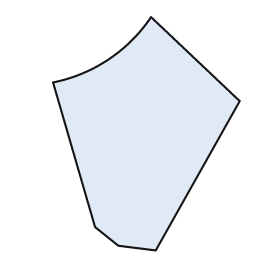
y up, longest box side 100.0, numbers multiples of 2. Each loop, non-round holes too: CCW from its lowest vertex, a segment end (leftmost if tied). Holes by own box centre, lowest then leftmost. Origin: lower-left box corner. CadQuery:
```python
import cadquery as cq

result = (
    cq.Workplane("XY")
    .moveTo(44.0, 0.0)
    .lineTo(80.0, 64.0)
    .lineTo(42.0, 100.0)
    .threePointArc((24.0, 82.0), (0.0, 72.0))
    .lineTo(18.0, 10.0)
    .lineTo(28.0, 2.0)
    .close()
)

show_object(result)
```